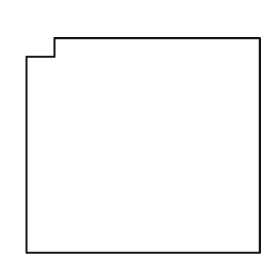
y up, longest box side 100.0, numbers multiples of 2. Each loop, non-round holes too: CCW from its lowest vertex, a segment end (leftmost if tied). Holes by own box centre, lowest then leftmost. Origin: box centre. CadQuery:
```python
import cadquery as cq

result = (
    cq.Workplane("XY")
    .moveTo(-50.0, -46.0)
    .lineTo(50.0, -46.0)
    .lineTo(50.0, 46.0)
    .lineTo(-38.0, 46.0)
    .lineTo(-38.0, 38.0)
    .lineTo(-50.0, 38.0)
    .close()
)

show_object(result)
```